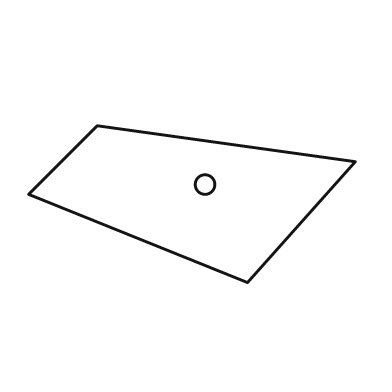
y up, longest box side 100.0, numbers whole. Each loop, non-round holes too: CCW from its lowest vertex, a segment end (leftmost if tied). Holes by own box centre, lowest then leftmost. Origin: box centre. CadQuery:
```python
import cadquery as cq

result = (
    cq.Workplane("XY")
    .moveTo(17.0, -24.0)
    .lineTo(50.0, 13.0)
    .lineTo(-29.0, 24.0)
    .lineTo(-50.0, 3.0)
    .close()
    .moveTo(4.0, 6.0)
    .circle(3.0)
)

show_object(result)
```